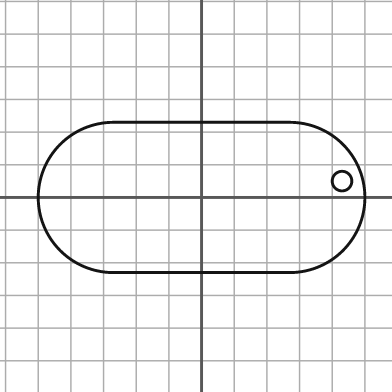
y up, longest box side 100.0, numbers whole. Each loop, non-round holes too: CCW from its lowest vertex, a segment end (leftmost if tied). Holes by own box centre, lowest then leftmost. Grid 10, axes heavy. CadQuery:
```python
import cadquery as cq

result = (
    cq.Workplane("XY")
    .moveTo(-27.0, -23.0)
    .lineTo(27.0, -23.0)
    .threePointArc((50.0, 0.0), (27.0, 23.0))
    .lineTo(-27.0, 23.0)
    .threePointArc((-50.0, 0.0), (-27.0, -23.0))
    .close()
    .moveTo(43.0, 5.0)
    .circle(3.0)
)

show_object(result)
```